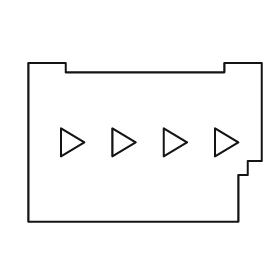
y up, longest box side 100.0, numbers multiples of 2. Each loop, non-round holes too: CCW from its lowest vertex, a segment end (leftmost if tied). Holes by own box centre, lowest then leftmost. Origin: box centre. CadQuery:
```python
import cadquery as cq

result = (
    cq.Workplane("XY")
    .moveTo(-50.0, -34.0)
    .lineTo(40.0, -34.0)
    .lineTo(40.0, -14.0)
    .lineTo(44.0, -14.0)
    .lineTo(44.0, -8.0)
    .lineTo(50.0, -8.0)
    .lineTo(50.0, 34.0)
    .lineTo(34.0, 34.0)
    .lineTo(34.0, 30.0)
    .lineTo(-34.0, 30.0)
    .lineTo(-34.0, 34.0)
    .lineTo(-50.0, 34.0)
    .close()
    .moveTo(-36.0, -6.0)
    .lineTo(-26.0, 0.0)
    .lineTo(-36.0, 6.0)
    .close()
    .moveTo(-14.0, -6.0)
    .lineTo(-4.0, 0.0)
    .lineTo(-14.0, 6.0)
    .close()
    .moveTo(8.0, -6.0)
    .lineTo(18.0, 0.0)
    .lineTo(8.0, 6.0)
    .close()
    .moveTo(30.0, -6.0)
    .lineTo(40.0, 0.0)
    .lineTo(30.0, 6.0)
    .close()
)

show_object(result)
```